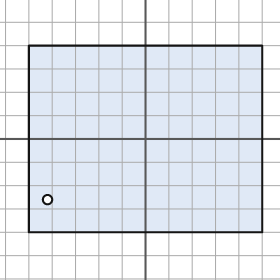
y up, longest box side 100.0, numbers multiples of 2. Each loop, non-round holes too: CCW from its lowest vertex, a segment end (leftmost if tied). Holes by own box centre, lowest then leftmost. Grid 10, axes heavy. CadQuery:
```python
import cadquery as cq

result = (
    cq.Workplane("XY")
    .moveTo(-50.0, -40.0)
    .lineTo(50.0, -40.0)
    .lineTo(50.0, 40.0)
    .lineTo(-50.0, 40.0)
    .close()
    .moveTo(-42.0, -26.0)
    .circle(2.0)
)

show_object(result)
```